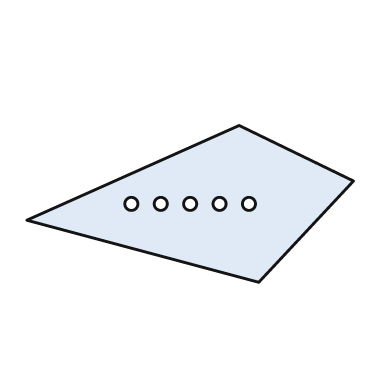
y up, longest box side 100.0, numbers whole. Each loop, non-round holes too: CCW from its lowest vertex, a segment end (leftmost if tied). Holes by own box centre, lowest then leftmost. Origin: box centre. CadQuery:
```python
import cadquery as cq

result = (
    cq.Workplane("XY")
    .moveTo(21.0, -24.0)
    .lineTo(50.0, 7.0)
    .lineTo(15.0, 24.0)
    .lineTo(-50.0, -5.0)
    .close()
    .moveTo(-18.0, 0.0)
    .circle(2.0)
    .moveTo(-9.0, 0.0)
    .circle(2.0)
    .moveTo(0.0, 0.0)
    .circle(2.0)
    .moveTo(9.0, 0.0)
    .circle(2.0)
    .moveTo(18.0, 0.0)
    .circle(2.0)
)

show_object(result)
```